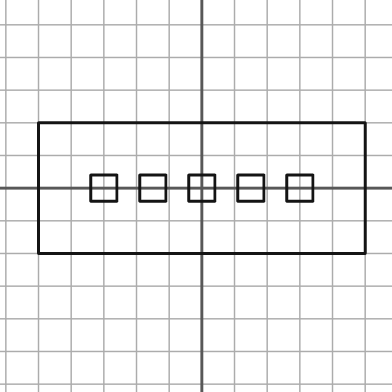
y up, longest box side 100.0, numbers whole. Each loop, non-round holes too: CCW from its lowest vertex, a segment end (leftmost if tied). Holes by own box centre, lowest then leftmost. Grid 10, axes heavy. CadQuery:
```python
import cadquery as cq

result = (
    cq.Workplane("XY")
    .moveTo(-50.0, -20.0)
    .lineTo(50.0, -20.0)
    .lineTo(50.0, 20.0)
    .lineTo(-50.0, 20.0)
    .close()
    .moveTo(-34.0, -4.0)
    .lineTo(-26.0, -4.0)
    .lineTo(-26.0, 4.0)
    .lineTo(-34.0, 4.0)
    .close()
    .moveTo(-19.0, -4.0)
    .lineTo(-11.0, -4.0)
    .lineTo(-11.0, 4.0)
    .lineTo(-19.0, 4.0)
    .close()
    .moveTo(-4.0, -4.0)
    .lineTo(4.0, -4.0)
    .lineTo(4.0, 4.0)
    .lineTo(-4.0, 4.0)
    .close()
    .moveTo(11.0, -4.0)
    .lineTo(19.0, -4.0)
    .lineTo(19.0, 4.0)
    .lineTo(11.0, 4.0)
    .close()
    .moveTo(26.0, -4.0)
    .lineTo(34.0, -4.0)
    .lineTo(34.0, 4.0)
    .lineTo(26.0, 4.0)
    .close()
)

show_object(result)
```